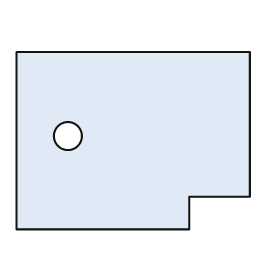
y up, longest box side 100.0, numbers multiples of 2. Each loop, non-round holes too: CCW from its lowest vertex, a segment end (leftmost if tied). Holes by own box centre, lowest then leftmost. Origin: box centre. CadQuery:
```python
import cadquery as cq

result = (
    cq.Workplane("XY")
    .moveTo(-50.0, -38.0)
    .lineTo(24.0, -38.0)
    .lineTo(24.0, -24.0)
    .lineTo(50.0, -24.0)
    .lineTo(50.0, 38.0)
    .lineTo(-50.0, 38.0)
    .close()
    .moveTo(-28.0, 2.0)
    .circle(6.0)
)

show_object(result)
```